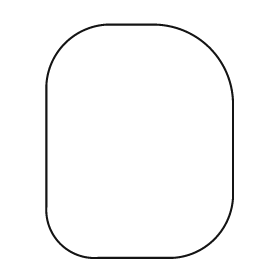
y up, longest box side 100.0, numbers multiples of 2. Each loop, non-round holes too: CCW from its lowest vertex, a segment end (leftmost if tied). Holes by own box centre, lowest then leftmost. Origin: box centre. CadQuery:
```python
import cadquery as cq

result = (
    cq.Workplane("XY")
    .moveTo(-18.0, -50.0)
    .lineTo(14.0, -50.0)
    .threePointArc((32.0, -42.0), (40.0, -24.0))
    .lineTo(40.0, 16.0)
    .threePointArc((30.0, 40.0), (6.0, 50.0))
    .lineTo(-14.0, 50.0)
    .threePointArc((-32.0, 42.0), (-40.0, 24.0))
    .lineTo(-40.0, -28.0)
    .threePointArc((-34.0, -44.0), (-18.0, -50.0))
    .close()
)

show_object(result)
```